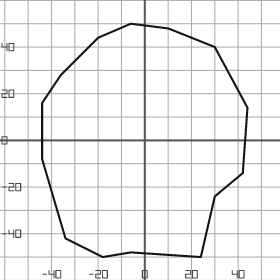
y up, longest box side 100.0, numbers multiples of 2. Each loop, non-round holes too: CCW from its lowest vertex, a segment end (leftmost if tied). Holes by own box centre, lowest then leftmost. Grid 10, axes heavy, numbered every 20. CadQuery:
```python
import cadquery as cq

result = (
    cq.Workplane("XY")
    .moveTo(-18.0, -50.0)
    .lineTo(-6.0, -48.0)
    .lineTo(24.0, -50.0)
    .lineTo(30.0, -24.0)
    .lineTo(42.0, -14.0)
    .lineTo(44.0, 14.0)
    .lineTo(30.0, 40.0)
    .lineTo(10.0, 48.0)
    .lineTo(-6.0, 50.0)
    .lineTo(-20.0, 44.0)
    .lineTo(-36.0, 28.0)
    .lineTo(-44.0, 16.0)
    .lineTo(-44.0, -8.0)
    .lineTo(-34.0, -42.0)
    .close()
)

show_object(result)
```